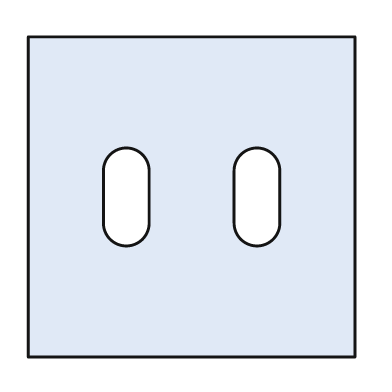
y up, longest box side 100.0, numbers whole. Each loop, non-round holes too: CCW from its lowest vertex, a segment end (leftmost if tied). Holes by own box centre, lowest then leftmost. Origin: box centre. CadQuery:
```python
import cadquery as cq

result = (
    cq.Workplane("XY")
    .moveTo(-50.0, -49.0)
    .lineTo(50.0, -49.0)
    .lineTo(50.0, 49.0)
    .lineTo(-50.0, 49.0)
    .close()
    .moveTo(-27.0, -8.0)
    .threePointArc((-20.0, -15.0), (-13.0, -8.0))
    .lineTo(-13.0, 8.0)
    .threePointArc((-20.0, 15.0), (-27.0, 8.0))
    .close()
    .moveTo(13.0, -8.0)
    .threePointArc((20.0, -15.0), (27.0, -8.0))
    .lineTo(27.0, 8.0)
    .threePointArc((20.0, 15.0), (13.0, 8.0))
    .close()
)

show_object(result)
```